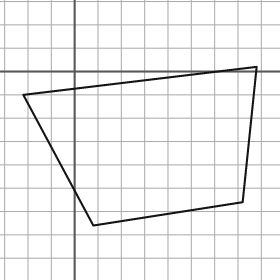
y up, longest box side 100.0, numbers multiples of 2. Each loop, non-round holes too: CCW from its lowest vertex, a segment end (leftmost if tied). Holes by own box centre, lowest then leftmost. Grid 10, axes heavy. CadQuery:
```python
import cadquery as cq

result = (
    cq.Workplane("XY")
    .moveTo(8.0, -66.0)
    .lineTo(72.0, -56.0)
    .lineTo(78.0, 2.0)
    .lineTo(-22.0, -10.0)
    .close()
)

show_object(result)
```